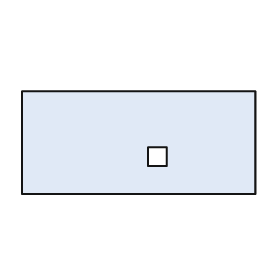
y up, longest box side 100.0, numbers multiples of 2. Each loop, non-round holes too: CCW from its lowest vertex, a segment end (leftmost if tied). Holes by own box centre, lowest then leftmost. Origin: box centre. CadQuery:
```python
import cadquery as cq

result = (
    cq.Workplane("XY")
    .moveTo(-50.0, -22.0)
    .lineTo(50.0, -22.0)
    .lineTo(50.0, 22.0)
    .lineTo(-50.0, 22.0)
    .close()
    .moveTo(4.0, -10.0)
    .lineTo(12.0, -10.0)
    .lineTo(12.0, -2.0)
    .lineTo(4.0, -2.0)
    .close()
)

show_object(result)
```